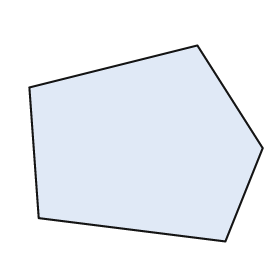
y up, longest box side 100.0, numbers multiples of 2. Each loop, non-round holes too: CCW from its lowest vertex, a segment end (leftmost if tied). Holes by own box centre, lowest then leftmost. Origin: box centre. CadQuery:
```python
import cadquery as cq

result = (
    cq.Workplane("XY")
    .moveTo(34.0, -42.0)
    .lineTo(50.0, -2.0)
    .lineTo(22.0, 42.0)
    .lineTo(-50.0, 24.0)
    .lineTo(-46.0, -32.0)
    .close()
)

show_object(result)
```